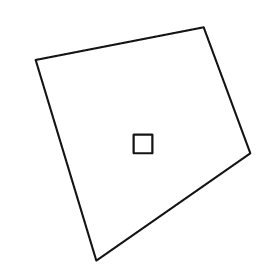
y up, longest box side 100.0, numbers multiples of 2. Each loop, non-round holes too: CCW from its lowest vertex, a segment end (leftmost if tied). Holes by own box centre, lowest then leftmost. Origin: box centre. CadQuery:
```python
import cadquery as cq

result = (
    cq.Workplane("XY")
    .moveTo(-20.0, -50.0)
    .lineTo(46.0, -4.0)
    .lineTo(26.0, 50.0)
    .lineTo(-46.0, 36.0)
    .close()
    .moveTo(-4.0, -4.0)
    .lineTo(4.0, -4.0)
    .lineTo(4.0, 4.0)
    .lineTo(-4.0, 4.0)
    .close()
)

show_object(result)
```